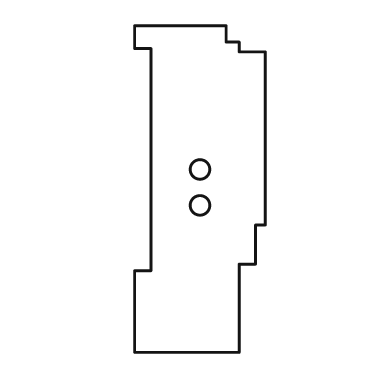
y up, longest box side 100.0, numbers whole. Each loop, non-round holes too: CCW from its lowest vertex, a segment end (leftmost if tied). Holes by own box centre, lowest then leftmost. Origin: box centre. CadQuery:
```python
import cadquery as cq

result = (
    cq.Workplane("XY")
    .moveTo(-20.0, -50.0)
    .lineTo(12.0, -50.0)
    .lineTo(12.0, -23.0)
    .lineTo(17.0, -23.0)
    .lineTo(17.0, -11.0)
    .lineTo(20.0, -11.0)
    .lineTo(20.0, 42.0)
    .lineTo(12.0, 42.0)
    .lineTo(12.0, 45.0)
    .lineTo(8.0, 45.0)
    .lineTo(8.0, 50.0)
    .lineTo(-20.0, 50.0)
    .lineTo(-20.0, 43.0)
    .lineTo(-15.0, 43.0)
    .lineTo(-15.0, -25.0)
    .lineTo(-20.0, -25.0)
    .close()
    .moveTo(0.0, -5.0)
    .circle(3.0)
    .moveTo(0.0, 6.0)
    .circle(3.0)
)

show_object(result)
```